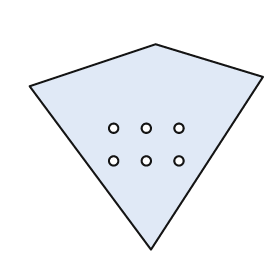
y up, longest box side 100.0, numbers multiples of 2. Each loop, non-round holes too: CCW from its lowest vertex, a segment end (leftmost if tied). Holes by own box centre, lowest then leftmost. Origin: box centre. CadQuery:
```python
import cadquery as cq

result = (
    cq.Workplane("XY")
    .moveTo(2.0, -44.0)
    .lineTo(50.0, 30.0)
    .lineTo(4.0, 44.0)
    .lineTo(-50.0, 26.0)
    .close()
    .moveTo(-14.0, -6.0)
    .circle(2.0)
    .moveTo(0.0, -6.0)
    .circle(2.0)
    .moveTo(14.0, -6.0)
    .circle(2.0)
    .moveTo(-14.0, 8.0)
    .circle(2.0)
    .moveTo(0.0, 8.0)
    .circle(2.0)
    .moveTo(14.0, 8.0)
    .circle(2.0)
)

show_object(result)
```